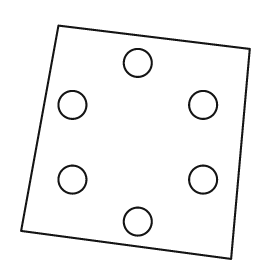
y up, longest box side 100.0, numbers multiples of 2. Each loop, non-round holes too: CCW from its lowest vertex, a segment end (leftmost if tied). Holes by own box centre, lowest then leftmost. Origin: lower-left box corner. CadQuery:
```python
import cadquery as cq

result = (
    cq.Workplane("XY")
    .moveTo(90.0, 0.0)
    .lineTo(98.0, 90.0)
    .lineTo(16.0, 100.0)
    .lineTo(0.0, 12.0)
    .close()
    .moveTo(50.0, 16.0)
    .circle(6.0)
    .moveTo(22.0, 34.0)
    .circle(6.0)
    .moveTo(78.0, 34.0)
    .circle(6.0)
    .moveTo(22.0, 66.0)
    .circle(6.0)
    .moveTo(78.0, 66.0)
    .circle(6.0)
    .moveTo(50.0, 84.0)
    .circle(6.0)
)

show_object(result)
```